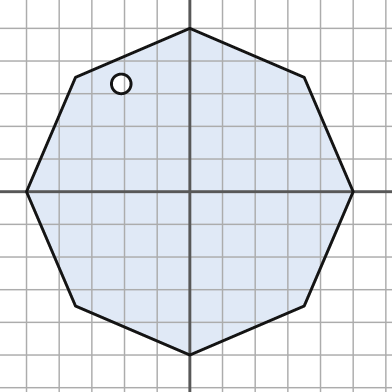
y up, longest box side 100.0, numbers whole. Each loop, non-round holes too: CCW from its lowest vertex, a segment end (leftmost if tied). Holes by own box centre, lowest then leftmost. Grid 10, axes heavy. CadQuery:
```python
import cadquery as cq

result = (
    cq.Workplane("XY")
    .moveTo(0.0, -50.0)
    .lineTo(35.0, -35.0)
    .lineTo(50.0, 0.0)
    .lineTo(35.0, 35.0)
    .lineTo(0.0, 50.0)
    .lineTo(-35.0, 35.0)
    .lineTo(-50.0, 0.0)
    .lineTo(-35.0, -35.0)
    .close()
    .moveTo(-21.0, 33.0)
    .circle(3.0)
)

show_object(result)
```